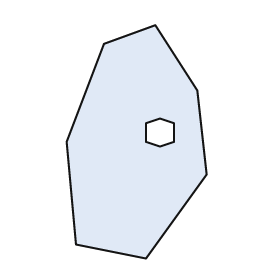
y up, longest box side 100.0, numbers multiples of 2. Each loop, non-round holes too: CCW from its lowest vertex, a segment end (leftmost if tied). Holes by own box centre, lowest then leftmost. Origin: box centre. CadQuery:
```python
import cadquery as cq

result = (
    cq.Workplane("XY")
    .moveTo(4.0, -50.0)
    .lineTo(30.0, -14.0)
    .lineTo(26.0, 22.0)
    .lineTo(8.0, 50.0)
    .lineTo(-14.0, 42.0)
    .lineTo(-30.0, 0.0)
    .lineTo(-26.0, -44.0)
    .close()
    .moveTo(10.0, -2.0)
    .lineTo(16.0, 0.0)
    .lineTo(16.0, 8.0)
    .lineTo(10.0, 10.0)
    .lineTo(4.0, 8.0)
    .lineTo(4.0, 0.0)
    .close()
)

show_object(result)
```